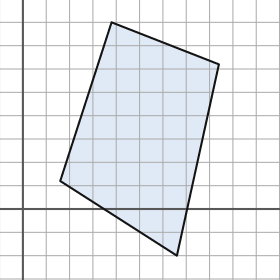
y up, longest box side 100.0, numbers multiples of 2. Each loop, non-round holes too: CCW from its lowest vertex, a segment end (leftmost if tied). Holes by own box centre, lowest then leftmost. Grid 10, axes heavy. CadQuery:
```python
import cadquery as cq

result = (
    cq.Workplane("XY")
    .moveTo(66.0, -20.0)
    .lineTo(84.0, 62.0)
    .lineTo(38.0, 80.0)
    .lineTo(16.0, 12.0)
    .close()
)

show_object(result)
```